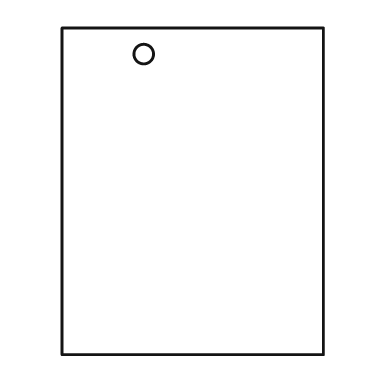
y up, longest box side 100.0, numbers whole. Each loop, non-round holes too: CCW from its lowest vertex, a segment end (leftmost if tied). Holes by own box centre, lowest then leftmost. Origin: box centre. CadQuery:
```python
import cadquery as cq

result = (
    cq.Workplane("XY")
    .moveTo(-40.0, -50.0)
    .lineTo(40.0, -50.0)
    .lineTo(40.0, 50.0)
    .lineTo(-40.0, 50.0)
    .close()
    .moveTo(-15.0, 42.0)
    .circle(3.0)
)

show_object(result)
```